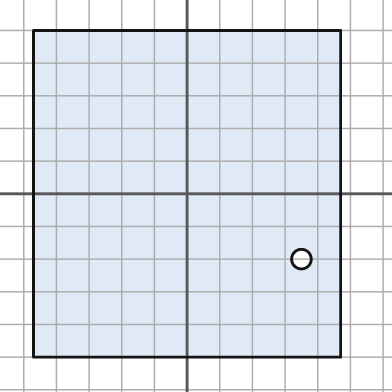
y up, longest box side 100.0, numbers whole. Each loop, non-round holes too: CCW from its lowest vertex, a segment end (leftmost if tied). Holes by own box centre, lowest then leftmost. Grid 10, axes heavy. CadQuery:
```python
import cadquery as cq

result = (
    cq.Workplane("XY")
    .moveTo(-47.0, -50.0)
    .lineTo(47.0, -50.0)
    .lineTo(47.0, 50.0)
    .lineTo(-47.0, 50.0)
    .close()
    .moveTo(35.0, -20.0)
    .circle(3.0)
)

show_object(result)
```